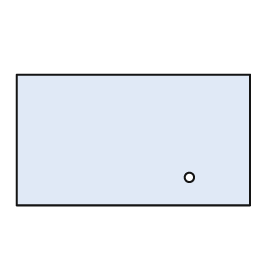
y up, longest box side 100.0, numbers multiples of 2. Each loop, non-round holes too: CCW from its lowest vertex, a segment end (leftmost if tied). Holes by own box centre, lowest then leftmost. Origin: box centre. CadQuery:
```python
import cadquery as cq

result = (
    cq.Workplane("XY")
    .moveTo(-50.0, -28.0)
    .lineTo(50.0, -28.0)
    .lineTo(50.0, 28.0)
    .lineTo(-50.0, 28.0)
    .close()
    .moveTo(24.0, -16.0)
    .circle(2.0)
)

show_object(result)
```